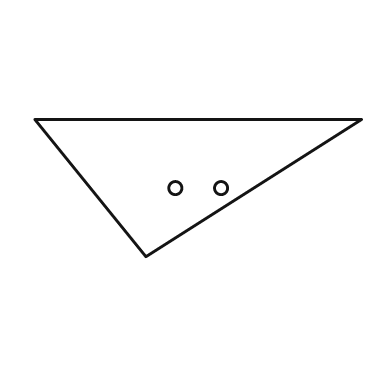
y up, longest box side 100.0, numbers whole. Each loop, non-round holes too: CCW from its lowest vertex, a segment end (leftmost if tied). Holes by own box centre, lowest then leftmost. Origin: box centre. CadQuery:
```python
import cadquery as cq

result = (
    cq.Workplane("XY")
    .moveTo(-16.0, -21.0)
    .lineTo(50.0, 21.0)
    .lineTo(-50.0, 21.0)
    .close()
    .moveTo(-7.0, 0.0)
    .circle(2.0)
    .moveTo(7.0, 0.0)
    .circle(2.0)
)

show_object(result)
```